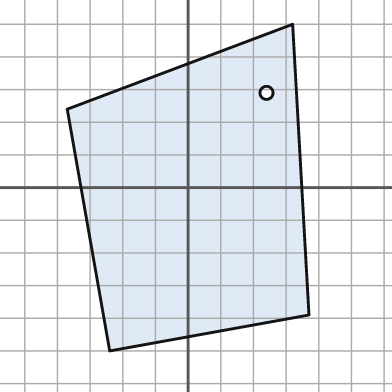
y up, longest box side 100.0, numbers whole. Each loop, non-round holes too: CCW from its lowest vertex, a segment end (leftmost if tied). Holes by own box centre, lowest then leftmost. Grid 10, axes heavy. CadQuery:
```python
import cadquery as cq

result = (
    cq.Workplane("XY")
    .moveTo(-24.0, -50.0)
    .lineTo(37.0, -39.0)
    .lineTo(32.0, 50.0)
    .lineTo(-37.0, 24.0)
    .close()
    .moveTo(24.0, 29.0)
    .circle(2.0)
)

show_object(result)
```